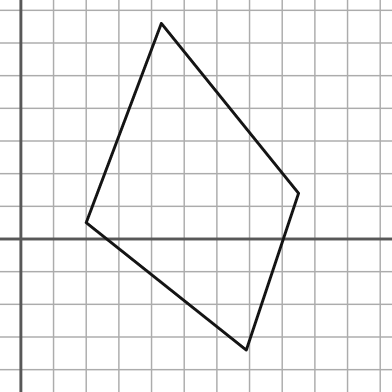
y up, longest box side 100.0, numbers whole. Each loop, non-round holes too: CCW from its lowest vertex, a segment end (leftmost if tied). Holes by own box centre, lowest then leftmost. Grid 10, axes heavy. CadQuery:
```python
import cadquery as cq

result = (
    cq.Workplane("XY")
    .moveTo(69.0, -34.0)
    .lineTo(85.0, 14.0)
    .lineTo(43.0, 66.0)
    .lineTo(20.0, 5.0)
    .close()
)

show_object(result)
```